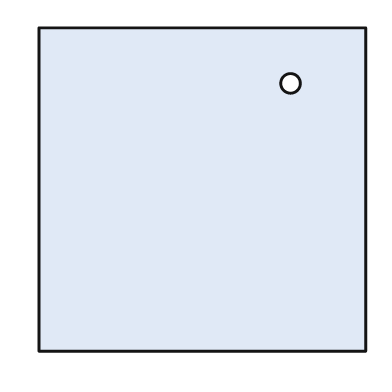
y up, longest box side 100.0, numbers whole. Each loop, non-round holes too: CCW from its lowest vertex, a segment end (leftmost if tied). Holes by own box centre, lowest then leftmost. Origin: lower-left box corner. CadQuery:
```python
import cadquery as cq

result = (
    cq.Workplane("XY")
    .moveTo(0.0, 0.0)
    .lineTo(100.0, 0.0)
    .lineTo(100.0, 99.0)
    .lineTo(0.0, 99.0)
    .close()
    .moveTo(77.0, 82.0)
    .circle(3.0)
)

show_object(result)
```